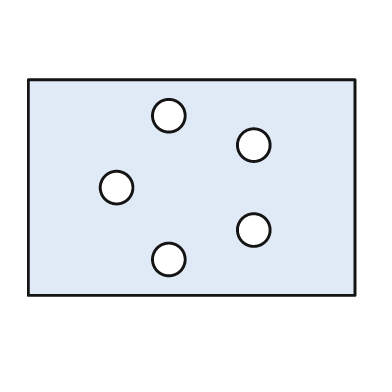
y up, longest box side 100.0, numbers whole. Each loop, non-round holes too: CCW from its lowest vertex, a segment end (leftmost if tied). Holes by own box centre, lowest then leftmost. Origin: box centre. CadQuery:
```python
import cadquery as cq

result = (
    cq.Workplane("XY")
    .moveTo(-50.0, -33.0)
    .lineTo(50.0, -33.0)
    .lineTo(50.0, 33.0)
    .lineTo(-50.0, 33.0)
    .close()
    .moveTo(-7.0, -22.0)
    .circle(5.0)
    .moveTo(19.0, -13.0)
    .circle(5.0)
    .moveTo(-23.0, 0.0)
    .circle(5.0)
    .moveTo(19.0, 13.0)
    .circle(5.0)
    .moveTo(-7.0, 22.0)
    .circle(5.0)
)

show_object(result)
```